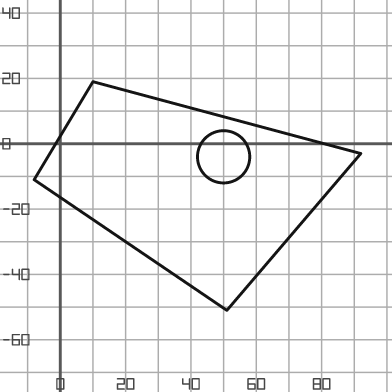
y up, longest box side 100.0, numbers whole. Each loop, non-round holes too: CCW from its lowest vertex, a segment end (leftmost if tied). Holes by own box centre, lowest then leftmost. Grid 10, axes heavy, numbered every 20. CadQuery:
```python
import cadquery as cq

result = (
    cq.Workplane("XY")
    .moveTo(51.0, -51.0)
    .lineTo(92.0, -3.0)
    .lineTo(10.0, 19.0)
    .lineTo(-8.0, -11.0)
    .close()
    .moveTo(50.0, -4.0)
    .circle(8.0)
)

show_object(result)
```